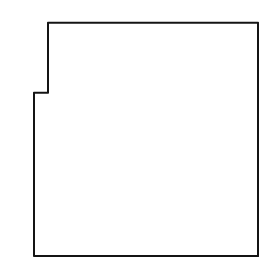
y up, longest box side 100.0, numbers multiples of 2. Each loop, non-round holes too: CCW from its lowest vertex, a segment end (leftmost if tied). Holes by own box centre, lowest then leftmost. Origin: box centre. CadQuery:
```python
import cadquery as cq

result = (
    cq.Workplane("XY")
    .moveTo(-48.0, -50.0)
    .lineTo(48.0, -50.0)
    .lineTo(48.0, 50.0)
    .lineTo(-42.0, 50.0)
    .lineTo(-42.0, 20.0)
    .lineTo(-48.0, 20.0)
    .close()
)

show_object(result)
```